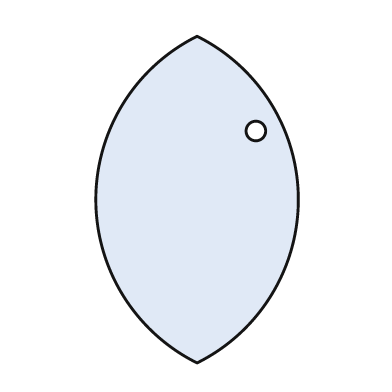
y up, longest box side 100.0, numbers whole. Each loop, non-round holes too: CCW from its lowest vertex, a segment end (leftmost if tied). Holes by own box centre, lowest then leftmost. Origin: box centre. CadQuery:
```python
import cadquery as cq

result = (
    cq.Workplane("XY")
    .moveTo(0.0, -50.0)
    .threePointArc((31.0, 0.0), (0.0, 50.0))
    .threePointArc((-31.0, 0.0), (0.0, -50.0))
    .close()
    .moveTo(18.0, 21.0)
    .circle(3.0)
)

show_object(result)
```